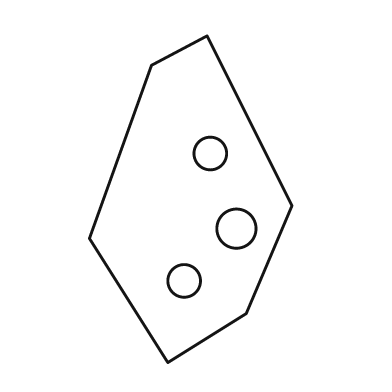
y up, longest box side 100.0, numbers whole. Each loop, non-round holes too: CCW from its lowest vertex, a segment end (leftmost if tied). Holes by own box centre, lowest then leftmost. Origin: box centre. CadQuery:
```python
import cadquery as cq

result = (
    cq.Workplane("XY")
    .moveTo(-7.0, -50.0)
    .lineTo(17.0, -35.0)
    .lineTo(31.0, -2.0)
    .lineTo(5.0, 50.0)
    .lineTo(-12.0, 41.0)
    .lineTo(-31.0, -12.0)
    .close()
    .moveTo(-2.0, -25.0)
    .circle(5.0)
    .moveTo(14.0, -9.0)
    .circle(6.0)
    .moveTo(6.0, 14.0)
    .circle(5.0)
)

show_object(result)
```